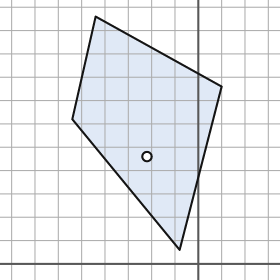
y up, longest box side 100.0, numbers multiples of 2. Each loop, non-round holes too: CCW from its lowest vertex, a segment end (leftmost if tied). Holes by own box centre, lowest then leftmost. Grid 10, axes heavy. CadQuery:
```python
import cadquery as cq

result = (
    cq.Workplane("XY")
    .moveTo(-8.0, 6.0)
    .lineTo(10.0, 76.0)
    .lineTo(-44.0, 106.0)
    .lineTo(-54.0, 62.0)
    .close()
    .moveTo(-22.0, 46.0)
    .circle(2.0)
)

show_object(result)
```